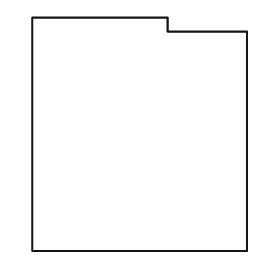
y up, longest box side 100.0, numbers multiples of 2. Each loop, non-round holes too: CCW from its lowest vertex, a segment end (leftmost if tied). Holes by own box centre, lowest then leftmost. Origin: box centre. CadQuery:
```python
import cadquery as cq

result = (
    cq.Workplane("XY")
    .moveTo(-46.0, -50.0)
    .lineTo(46.0, -50.0)
    .lineTo(46.0, 44.0)
    .lineTo(12.0, 44.0)
    .lineTo(12.0, 50.0)
    .lineTo(-46.0, 50.0)
    .close()
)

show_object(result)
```